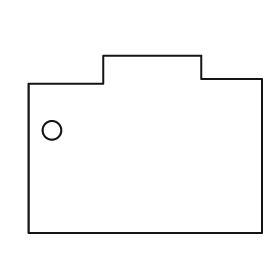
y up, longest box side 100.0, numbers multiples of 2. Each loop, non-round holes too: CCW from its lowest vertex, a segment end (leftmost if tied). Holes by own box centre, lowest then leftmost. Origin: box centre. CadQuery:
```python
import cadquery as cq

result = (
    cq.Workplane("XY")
    .moveTo(-50.0, -38.0)
    .lineTo(50.0, -38.0)
    .lineTo(50.0, 28.0)
    .lineTo(24.0, 28.0)
    .lineTo(24.0, 38.0)
    .lineTo(-18.0, 38.0)
    .lineTo(-18.0, 26.0)
    .lineTo(-50.0, 26.0)
    .close()
    .moveTo(-40.0, 6.0)
    .circle(4.0)
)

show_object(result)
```